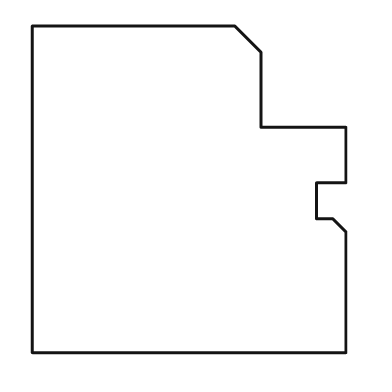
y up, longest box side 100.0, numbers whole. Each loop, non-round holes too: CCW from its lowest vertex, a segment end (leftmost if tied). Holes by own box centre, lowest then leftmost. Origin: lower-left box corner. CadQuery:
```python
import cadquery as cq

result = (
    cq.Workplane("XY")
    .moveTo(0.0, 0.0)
    .lineTo(96.0, 0.0)
    .lineTo(96.0, 37.0)
    .lineTo(92.0, 41.0)
    .lineTo(87.0, 41.0)
    .lineTo(87.0, 52.0)
    .lineTo(96.0, 52.0)
    .lineTo(96.0, 69.0)
    .lineTo(70.0, 69.0)
    .lineTo(70.0, 92.0)
    .lineTo(62.0, 100.0)
    .lineTo(0.0, 100.0)
    .close()
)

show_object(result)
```